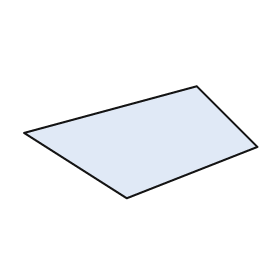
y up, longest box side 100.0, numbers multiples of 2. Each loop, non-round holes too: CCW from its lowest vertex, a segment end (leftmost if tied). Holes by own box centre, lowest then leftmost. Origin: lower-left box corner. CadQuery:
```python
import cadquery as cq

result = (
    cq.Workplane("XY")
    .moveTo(44.0, 0.0)
    .lineTo(100.0, 22.0)
    .lineTo(74.0, 48.0)
    .lineTo(0.0, 28.0)
    .close()
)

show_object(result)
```